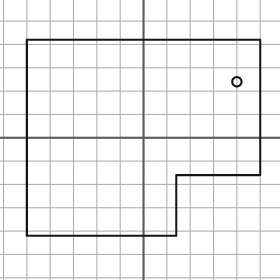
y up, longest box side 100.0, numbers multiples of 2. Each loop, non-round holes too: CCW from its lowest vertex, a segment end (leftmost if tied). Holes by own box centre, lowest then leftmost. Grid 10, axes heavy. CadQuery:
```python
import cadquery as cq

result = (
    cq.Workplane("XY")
    .moveTo(-50.0, -42.0)
    .lineTo(14.0, -42.0)
    .lineTo(14.0, -16.0)
    .lineTo(50.0, -16.0)
    .lineTo(50.0, 42.0)
    .lineTo(-50.0, 42.0)
    .close()
    .moveTo(40.0, 24.0)
    .circle(2.0)
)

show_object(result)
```